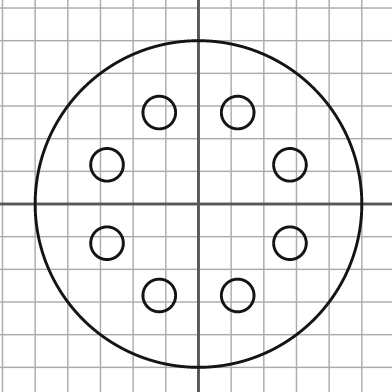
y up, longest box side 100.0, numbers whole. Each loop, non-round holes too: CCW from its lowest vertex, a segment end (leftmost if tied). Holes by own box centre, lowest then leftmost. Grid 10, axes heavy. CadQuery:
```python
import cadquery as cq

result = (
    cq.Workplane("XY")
    .moveTo(0.0, 0.0)
    .circle(50.0)
    .moveTo(-12.0, -28.0)
    .circle(5.0)
    .moveTo(12.0, -28.0)
    .circle(5.0)
    .moveTo(-28.0, -12.0)
    .circle(5.0)
    .moveTo(28.0, -12.0)
    .circle(5.0)
    .moveTo(-28.0, 12.0)
    .circle(5.0)
    .moveTo(28.0, 12.0)
    .circle(5.0)
    .moveTo(-12.0, 28.0)
    .circle(5.0)
    .moveTo(12.0, 28.0)
    .circle(5.0)
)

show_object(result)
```